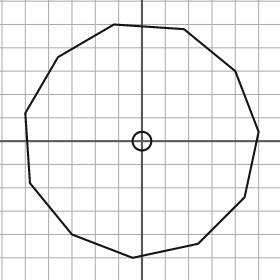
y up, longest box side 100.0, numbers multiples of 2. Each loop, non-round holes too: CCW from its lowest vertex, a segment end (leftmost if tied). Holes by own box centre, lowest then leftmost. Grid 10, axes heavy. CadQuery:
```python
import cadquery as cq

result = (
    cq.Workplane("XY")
    .moveTo(-4.0, -50.0)
    .lineTo(24.0, -44.0)
    .lineTo(44.0, -24.0)
    .lineTo(50.0, 4.0)
    .lineTo(40.0, 30.0)
    .lineTo(18.0, 48.0)
    .lineTo(-12.0, 50.0)
    .lineTo(-36.0, 36.0)
    .lineTo(-50.0, 12.0)
    .lineTo(-48.0, -18.0)
    .lineTo(-30.0, -40.0)
    .close()
    .moveTo(0.0, 0.0)
    .circle(4.0)
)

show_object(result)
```